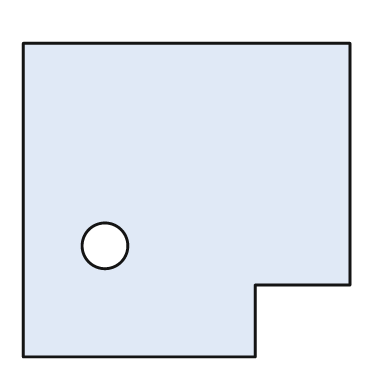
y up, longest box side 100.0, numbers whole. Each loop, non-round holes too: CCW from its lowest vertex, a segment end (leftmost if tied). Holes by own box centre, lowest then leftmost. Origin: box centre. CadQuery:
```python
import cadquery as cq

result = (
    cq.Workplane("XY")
    .moveTo(-50.0, -48.0)
    .lineTo(21.0, -48.0)
    .lineTo(21.0, -26.0)
    .lineTo(50.0, -26.0)
    .lineTo(50.0, 48.0)
    .lineTo(-50.0, 48.0)
    .close()
    .moveTo(-25.0, -14.0)
    .circle(7.0)
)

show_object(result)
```